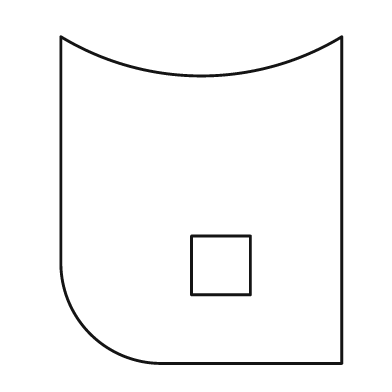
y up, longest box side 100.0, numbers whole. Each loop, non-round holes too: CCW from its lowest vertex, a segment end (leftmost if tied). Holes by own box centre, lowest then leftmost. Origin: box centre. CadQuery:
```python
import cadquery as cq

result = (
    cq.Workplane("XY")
    .moveTo(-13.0, -50.0)
    .lineTo(43.0, -50.0)
    .lineTo(43.0, 50.0)
    .threePointArc((0.0, 38.0), (-43.0, 50.0))
    .lineTo(-43.0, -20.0)
    .threePointArc((-34.0, -41.0), (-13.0, -50.0))
    .close()
    .moveTo(-3.0, -29.0)
    .lineTo(15.0, -29.0)
    .lineTo(15.0, -11.0)
    .lineTo(-3.0, -11.0)
    .close()
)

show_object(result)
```